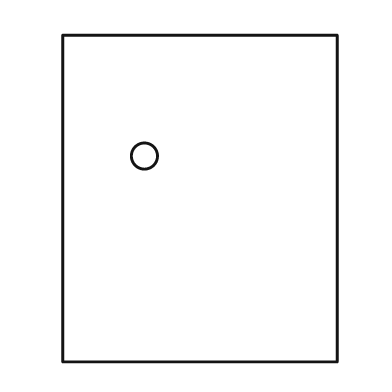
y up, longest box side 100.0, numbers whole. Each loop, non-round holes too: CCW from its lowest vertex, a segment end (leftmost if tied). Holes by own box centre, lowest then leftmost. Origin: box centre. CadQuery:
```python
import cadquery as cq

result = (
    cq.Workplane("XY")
    .moveTo(-42.0, -50.0)
    .lineTo(42.0, -50.0)
    .lineTo(42.0, 50.0)
    .lineTo(-42.0, 50.0)
    .close()
    .moveTo(-17.0, 13.0)
    .circle(4.0)
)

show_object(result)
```